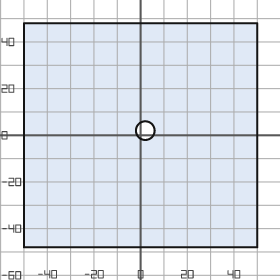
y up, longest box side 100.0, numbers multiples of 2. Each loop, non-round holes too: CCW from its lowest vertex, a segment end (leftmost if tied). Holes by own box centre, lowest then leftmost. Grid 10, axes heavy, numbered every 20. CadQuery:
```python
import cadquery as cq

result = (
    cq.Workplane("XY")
    .moveTo(-50.0, -48.0)
    .lineTo(50.0, -48.0)
    .lineTo(50.0, 48.0)
    .lineTo(-50.0, 48.0)
    .close()
    .moveTo(2.0, 2.0)
    .circle(4.0)
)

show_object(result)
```